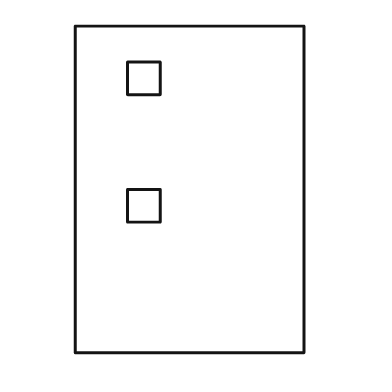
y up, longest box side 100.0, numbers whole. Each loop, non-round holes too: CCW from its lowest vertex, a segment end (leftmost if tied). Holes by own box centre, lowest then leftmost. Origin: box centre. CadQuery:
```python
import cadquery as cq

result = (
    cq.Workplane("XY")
    .moveTo(-35.0, -50.0)
    .lineTo(35.0, -50.0)
    .lineTo(35.0, 50.0)
    .lineTo(-35.0, 50.0)
    .close()
    .moveTo(-19.0, -10.0)
    .lineTo(-9.0, -10.0)
    .lineTo(-9.0, 0.0)
    .lineTo(-19.0, 0.0)
    .close()
    .moveTo(-19.0, 29.0)
    .lineTo(-9.0, 29.0)
    .lineTo(-9.0, 39.0)
    .lineTo(-19.0, 39.0)
    .close()
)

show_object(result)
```